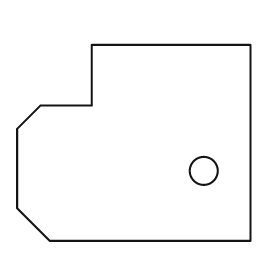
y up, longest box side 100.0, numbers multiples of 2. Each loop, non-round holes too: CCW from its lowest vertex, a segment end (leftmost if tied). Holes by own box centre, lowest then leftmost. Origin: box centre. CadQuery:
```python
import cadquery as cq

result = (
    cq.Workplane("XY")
    .moveTo(-36.0, -42.0)
    .lineTo(50.0, -42.0)
    .lineTo(50.0, 42.0)
    .lineTo(-18.0, 42.0)
    .lineTo(-18.0, 16.0)
    .lineTo(-40.0, 16.0)
    .lineTo(-50.0, 6.0)
    .lineTo(-50.0, -28.0)
    .close()
    .moveTo(30.0, -12.0)
    .circle(6.0)
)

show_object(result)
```